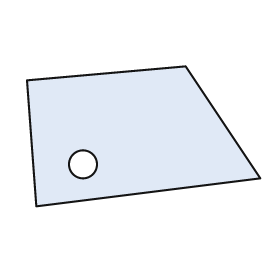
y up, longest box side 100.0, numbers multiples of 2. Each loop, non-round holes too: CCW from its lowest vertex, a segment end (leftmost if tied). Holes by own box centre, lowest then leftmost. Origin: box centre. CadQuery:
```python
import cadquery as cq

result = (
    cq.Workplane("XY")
    .moveTo(-46.0, -30.0)
    .lineTo(50.0, -18.0)
    .lineTo(18.0, 30.0)
    .lineTo(-50.0, 24.0)
    .close()
    .moveTo(-26.0, -12.0)
    .circle(6.0)
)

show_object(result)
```